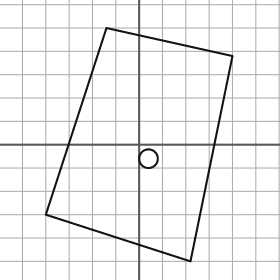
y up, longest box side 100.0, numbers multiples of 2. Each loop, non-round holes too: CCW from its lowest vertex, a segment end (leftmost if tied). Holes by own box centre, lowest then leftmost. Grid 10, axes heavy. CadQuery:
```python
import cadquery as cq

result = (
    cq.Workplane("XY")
    .moveTo(22.0, -50.0)
    .lineTo(40.0, 38.0)
    .lineTo(-14.0, 50.0)
    .lineTo(-40.0, -30.0)
    .close()
    .moveTo(4.0, -6.0)
    .circle(4.0)
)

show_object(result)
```